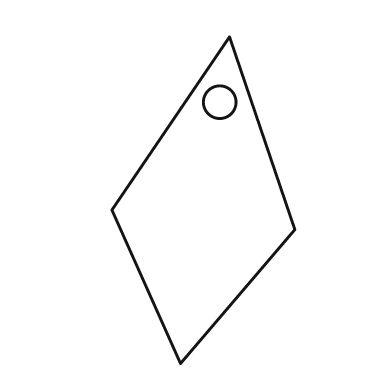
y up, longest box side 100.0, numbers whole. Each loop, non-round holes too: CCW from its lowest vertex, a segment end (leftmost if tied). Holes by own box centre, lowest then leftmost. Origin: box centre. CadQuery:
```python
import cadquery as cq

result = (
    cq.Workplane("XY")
    .moveTo(-7.0, -50.0)
    .lineTo(28.0, -9.0)
    .lineTo(8.0, 50.0)
    .lineTo(-28.0, -3.0)
    .close()
    .moveTo(5.0, 30.0)
    .circle(5.0)
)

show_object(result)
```